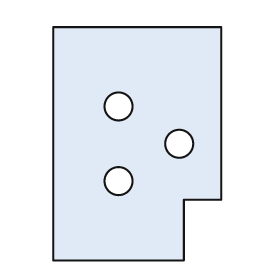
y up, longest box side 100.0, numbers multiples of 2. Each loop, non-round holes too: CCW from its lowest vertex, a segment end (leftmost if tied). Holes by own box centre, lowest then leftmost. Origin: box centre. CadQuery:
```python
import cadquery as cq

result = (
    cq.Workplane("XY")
    .moveTo(-36.0, -50.0)
    .lineTo(20.0, -50.0)
    .lineTo(20.0, -24.0)
    .lineTo(36.0, -24.0)
    .lineTo(36.0, 50.0)
    .lineTo(-36.0, 50.0)
    .close()
    .moveTo(-8.0, -16.0)
    .circle(6.0)
    .moveTo(18.0, 0.0)
    .circle(6.0)
    .moveTo(-8.0, 16.0)
    .circle(6.0)
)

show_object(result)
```